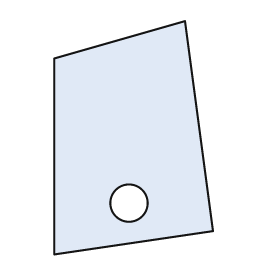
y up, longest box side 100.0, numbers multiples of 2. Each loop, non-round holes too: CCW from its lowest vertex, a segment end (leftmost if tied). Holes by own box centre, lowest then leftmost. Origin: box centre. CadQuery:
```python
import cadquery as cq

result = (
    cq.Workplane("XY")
    .moveTo(-34.0, -50.0)
    .lineTo(34.0, -40.0)
    .lineTo(22.0, 50.0)
    .lineTo(-34.0, 34.0)
    .close()
    .moveTo(-2.0, -28.0)
    .circle(8.0)
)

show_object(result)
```